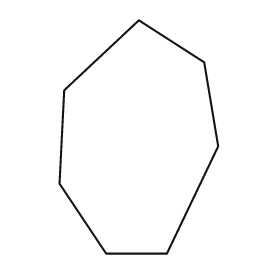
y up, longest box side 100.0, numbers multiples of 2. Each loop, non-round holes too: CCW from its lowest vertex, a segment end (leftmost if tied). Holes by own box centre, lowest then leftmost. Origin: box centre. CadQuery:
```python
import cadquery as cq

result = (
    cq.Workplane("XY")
    .moveTo(-14.0, -50.0)
    .lineTo(12.0, -50.0)
    .lineTo(34.0, -4.0)
    .lineTo(28.0, 32.0)
    .lineTo(0.0, 50.0)
    .lineTo(-32.0, 20.0)
    .lineTo(-34.0, -20.0)
    .close()
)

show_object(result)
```